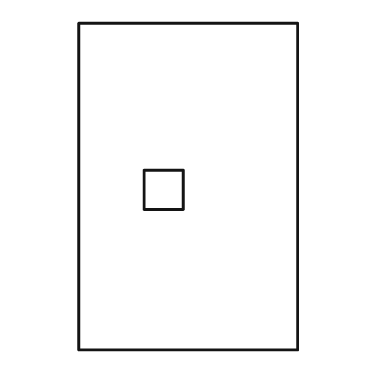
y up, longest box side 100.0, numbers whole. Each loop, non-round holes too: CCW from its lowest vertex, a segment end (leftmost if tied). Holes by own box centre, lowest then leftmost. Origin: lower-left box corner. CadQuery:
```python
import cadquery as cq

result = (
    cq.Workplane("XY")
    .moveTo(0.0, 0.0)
    .lineTo(67.0, 0.0)
    .lineTo(67.0, 100.0)
    .lineTo(0.0, 100.0)
    .close()
    .moveTo(20.0, 43.0)
    .lineTo(32.0, 43.0)
    .lineTo(32.0, 55.0)
    .lineTo(20.0, 55.0)
    .close()
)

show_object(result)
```